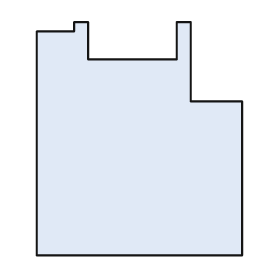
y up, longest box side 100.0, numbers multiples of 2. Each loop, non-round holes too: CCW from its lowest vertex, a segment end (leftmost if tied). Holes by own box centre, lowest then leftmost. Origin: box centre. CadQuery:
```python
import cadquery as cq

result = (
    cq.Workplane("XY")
    .moveTo(-44.0, -50.0)
    .lineTo(44.0, -50.0)
    .lineTo(44.0, 16.0)
    .lineTo(22.0, 16.0)
    .lineTo(22.0, 50.0)
    .lineTo(16.0, 50.0)
    .lineTo(16.0, 34.0)
    .lineTo(-22.0, 34.0)
    .lineTo(-22.0, 50.0)
    .lineTo(-28.0, 50.0)
    .lineTo(-28.0, 46.0)
    .lineTo(-44.0, 46.0)
    .close()
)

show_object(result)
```